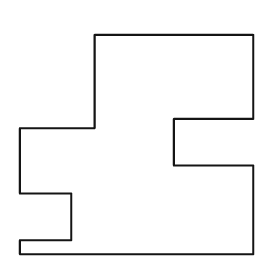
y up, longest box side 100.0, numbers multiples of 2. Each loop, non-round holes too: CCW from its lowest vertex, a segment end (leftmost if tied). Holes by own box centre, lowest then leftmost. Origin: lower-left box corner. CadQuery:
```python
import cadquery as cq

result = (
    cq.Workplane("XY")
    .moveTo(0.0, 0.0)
    .lineTo(100.0, 0.0)
    .lineTo(100.0, 38.0)
    .lineTo(66.0, 38.0)
    .lineTo(66.0, 58.0)
    .lineTo(100.0, 58.0)
    .lineTo(100.0, 94.0)
    .lineTo(32.0, 94.0)
    .lineTo(32.0, 54.0)
    .lineTo(0.0, 54.0)
    .lineTo(0.0, 26.0)
    .lineTo(22.0, 26.0)
    .lineTo(22.0, 6.0)
    .lineTo(0.0, 6.0)
    .close()
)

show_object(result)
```